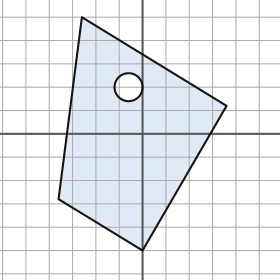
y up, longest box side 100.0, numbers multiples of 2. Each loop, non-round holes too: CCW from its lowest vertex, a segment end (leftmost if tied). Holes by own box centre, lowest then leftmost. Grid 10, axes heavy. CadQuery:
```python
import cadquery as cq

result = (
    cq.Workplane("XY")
    .moveTo(0.0, -50.0)
    .lineTo(36.0, 12.0)
    .lineTo(-26.0, 50.0)
    .lineTo(-36.0, -28.0)
    .close()
    .moveTo(-6.0, 20.0)
    .circle(6.0)
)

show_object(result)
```